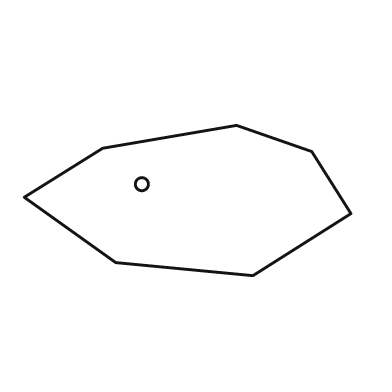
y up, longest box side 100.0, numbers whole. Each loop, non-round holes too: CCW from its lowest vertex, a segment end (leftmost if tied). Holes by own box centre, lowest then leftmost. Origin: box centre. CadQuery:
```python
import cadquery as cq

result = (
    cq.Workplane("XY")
    .moveTo(20.0, -23.0)
    .lineTo(50.0, -4.0)
    .lineTo(38.0, 15.0)
    .lineTo(15.0, 23.0)
    .lineTo(-26.0, 16.0)
    .lineTo(-50.0, 1.0)
    .lineTo(-22.0, -19.0)
    .close()
    .moveTo(-14.0, 5.0)
    .circle(2.0)
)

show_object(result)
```